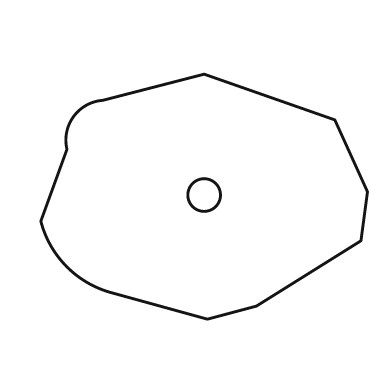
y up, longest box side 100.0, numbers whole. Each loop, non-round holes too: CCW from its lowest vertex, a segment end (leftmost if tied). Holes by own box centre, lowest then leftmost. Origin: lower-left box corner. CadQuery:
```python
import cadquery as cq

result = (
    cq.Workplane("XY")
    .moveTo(51.0, 0.0)
    .lineTo(66.0, 4.0)
    .lineTo(98.0, 24.0)
    .lineTo(100.0, 39.0)
    .lineTo(90.0, 61.0)
    .lineTo(50.0, 75.0)
    .lineTo(19.0, 67.0)
    .threePointArc((10.0, 62.0), (8.0, 52.0))
    .lineTo(0.0, 30.0)
    .threePointArc((8.0, 16.0), (22.0, 8.0))
    .close()
    .moveTo(50.0, 38.0)
    .circle(5.0)
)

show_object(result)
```